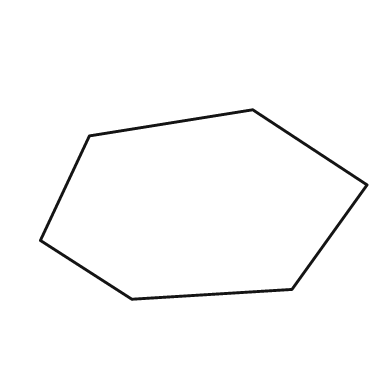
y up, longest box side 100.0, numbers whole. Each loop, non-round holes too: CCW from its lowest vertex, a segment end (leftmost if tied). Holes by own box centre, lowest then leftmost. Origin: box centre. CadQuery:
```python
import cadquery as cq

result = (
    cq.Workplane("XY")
    .moveTo(-22.0, -29.0)
    .lineTo(27.0, -26.0)
    .lineTo(50.0, 6.0)
    .lineTo(15.0, 29.0)
    .lineTo(-35.0, 21.0)
    .lineTo(-50.0, -11.0)
    .close()
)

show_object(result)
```